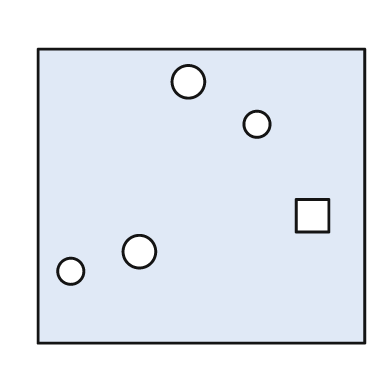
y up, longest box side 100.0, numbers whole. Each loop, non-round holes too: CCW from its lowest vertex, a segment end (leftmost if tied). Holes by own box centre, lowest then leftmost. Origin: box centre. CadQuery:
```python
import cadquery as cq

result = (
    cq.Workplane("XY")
    .moveTo(-50.0, -45.0)
    .lineTo(50.0, -45.0)
    .lineTo(50.0, 45.0)
    .lineTo(-50.0, 45.0)
    .close()
    .moveTo(-40.0, -23.0)
    .circle(4.0)
    .moveTo(-19.0, -17.0)
    .circle(5.0)
    .moveTo(29.0, -11.0)
    .lineTo(39.0, -11.0)
    .lineTo(39.0, -1.0)
    .lineTo(29.0, -1.0)
    .close()
    .moveTo(17.0, 22.0)
    .circle(4.0)
    .moveTo(-4.0, 35.0)
    .circle(5.0)
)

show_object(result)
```